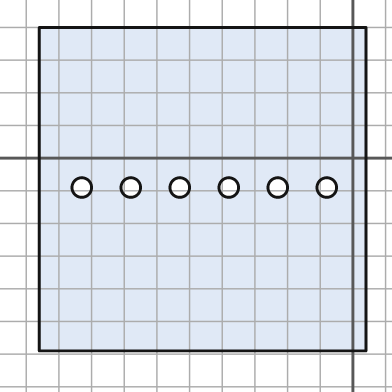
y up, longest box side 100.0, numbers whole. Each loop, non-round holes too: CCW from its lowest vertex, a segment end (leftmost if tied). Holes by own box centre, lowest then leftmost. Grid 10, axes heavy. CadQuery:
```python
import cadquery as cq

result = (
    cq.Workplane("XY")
    .moveTo(-96.0, -59.0)
    .lineTo(4.0, -59.0)
    .lineTo(4.0, 40.0)
    .lineTo(-96.0, 40.0)
    .close()
    .moveTo(-83.0, -9.0)
    .circle(3.0)
    .moveTo(-68.0, -9.0)
    .circle(3.0)
    .moveTo(-53.0, -9.0)
    .circle(3.0)
    .moveTo(-38.0, -9.0)
    .circle(3.0)
    .moveTo(-23.0, -9.0)
    .circle(3.0)
    .moveTo(-8.0, -9.0)
    .circle(3.0)
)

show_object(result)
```